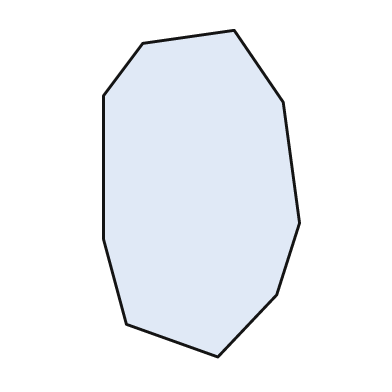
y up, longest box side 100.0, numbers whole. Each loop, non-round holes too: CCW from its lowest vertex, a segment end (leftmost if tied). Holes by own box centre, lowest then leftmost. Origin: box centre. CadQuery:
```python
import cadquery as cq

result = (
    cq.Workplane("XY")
    .moveTo(5.0, -50.0)
    .lineTo(23.0, -31.0)
    .lineTo(30.0, -9.0)
    .lineTo(25.0, 28.0)
    .lineTo(10.0, 50.0)
    .lineTo(-18.0, 46.0)
    .lineTo(-30.0, 30.0)
    .lineTo(-30.0, -14.0)
    .lineTo(-23.0, -40.0)
    .close()
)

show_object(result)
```